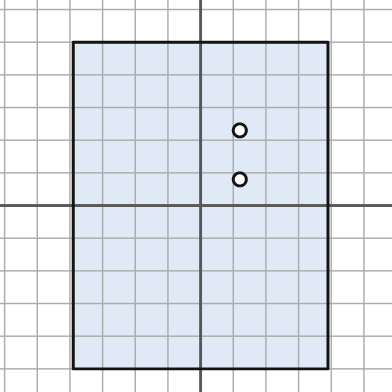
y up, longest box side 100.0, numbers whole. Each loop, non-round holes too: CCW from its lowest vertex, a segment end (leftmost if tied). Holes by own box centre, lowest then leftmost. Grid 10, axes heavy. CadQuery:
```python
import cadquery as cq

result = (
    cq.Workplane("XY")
    .moveTo(-39.0, -50.0)
    .lineTo(39.0, -50.0)
    .lineTo(39.0, 50.0)
    .lineTo(-39.0, 50.0)
    .close()
    .moveTo(12.0, 8.0)
    .circle(2.0)
    .moveTo(12.0, 23.0)
    .circle(2.0)
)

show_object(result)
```